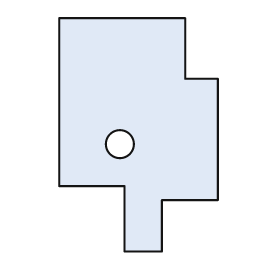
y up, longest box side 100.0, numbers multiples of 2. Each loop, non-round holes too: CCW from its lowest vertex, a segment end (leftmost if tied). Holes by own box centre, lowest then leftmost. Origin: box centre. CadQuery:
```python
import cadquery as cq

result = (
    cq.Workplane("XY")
    .moveTo(-6.0, -50.0)
    .lineTo(10.0, -50.0)
    .lineTo(10.0, -28.0)
    .lineTo(34.0, -28.0)
    .lineTo(34.0, 24.0)
    .lineTo(20.0, 24.0)
    .lineTo(20.0, 50.0)
    .lineTo(-34.0, 50.0)
    .lineTo(-34.0, -22.0)
    .lineTo(-6.0, -22.0)
    .close()
    .moveTo(-8.0, -4.0)
    .circle(6.0)
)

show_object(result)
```